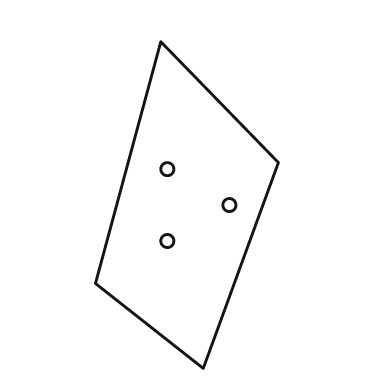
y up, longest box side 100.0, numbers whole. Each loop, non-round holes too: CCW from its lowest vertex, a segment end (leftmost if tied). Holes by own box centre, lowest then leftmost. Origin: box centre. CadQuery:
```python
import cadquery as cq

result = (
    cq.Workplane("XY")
    .moveTo(5.0, -50.0)
    .lineTo(28.0, 13.0)
    .lineTo(-8.0, 50.0)
    .lineTo(-28.0, -24.0)
    .close()
    .moveTo(-6.0, -11.0)
    .circle(2.0)
    .moveTo(13.0, 0.0)
    .circle(2.0)
    .moveTo(-6.0, 11.0)
    .circle(2.0)
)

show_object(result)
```